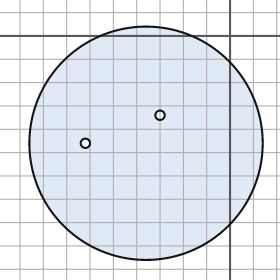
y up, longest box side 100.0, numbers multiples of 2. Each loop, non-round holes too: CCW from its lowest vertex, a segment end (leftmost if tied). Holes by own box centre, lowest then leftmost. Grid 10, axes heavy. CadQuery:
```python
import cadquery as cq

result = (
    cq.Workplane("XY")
    .moveTo(-36.0, -46.0)
    .circle(50.0)
    .moveTo(-62.0, -46.0)
    .circle(2.0)
    .moveTo(-30.0, -34.0)
    .circle(2.0)
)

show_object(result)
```